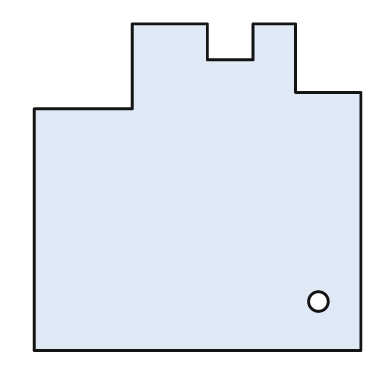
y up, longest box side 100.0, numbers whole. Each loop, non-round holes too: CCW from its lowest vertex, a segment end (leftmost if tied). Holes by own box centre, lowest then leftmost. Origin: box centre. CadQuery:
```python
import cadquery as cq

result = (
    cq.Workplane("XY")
    .moveTo(-50.0, -50.0)
    .lineTo(50.0, -50.0)
    .lineTo(50.0, 29.0)
    .lineTo(30.0, 29.0)
    .lineTo(30.0, 50.0)
    .lineTo(17.0, 50.0)
    .lineTo(17.0, 39.0)
    .lineTo(3.0, 39.0)
    .lineTo(3.0, 50.0)
    .lineTo(-20.0, 50.0)
    .lineTo(-20.0, 24.0)
    .lineTo(-50.0, 24.0)
    .close()
    .moveTo(37.0, -35.0)
    .circle(3.0)
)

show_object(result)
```